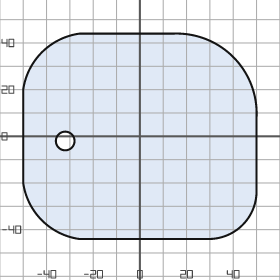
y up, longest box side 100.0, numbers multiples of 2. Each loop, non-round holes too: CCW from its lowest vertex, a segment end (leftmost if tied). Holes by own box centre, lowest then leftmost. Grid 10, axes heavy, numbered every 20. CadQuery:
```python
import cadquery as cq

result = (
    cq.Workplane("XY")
    .moveTo(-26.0, -44.0)
    .lineTo(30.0, -44.0)
    .threePointArc((44.0, -38.0), (50.0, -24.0))
    .lineTo(50.0, 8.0)
    .threePointArc((40.0, 34.0), (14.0, 44.0))
    .lineTo(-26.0, 44.0)
    .threePointArc((-42.0, 36.0), (-50.0, 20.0))
    .lineTo(-50.0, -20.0)
    .threePointArc((-42.0, -36.0), (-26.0, -44.0))
    .close()
    .moveTo(-32.0, -2.0)
    .circle(4.0)
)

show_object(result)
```